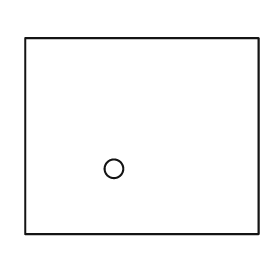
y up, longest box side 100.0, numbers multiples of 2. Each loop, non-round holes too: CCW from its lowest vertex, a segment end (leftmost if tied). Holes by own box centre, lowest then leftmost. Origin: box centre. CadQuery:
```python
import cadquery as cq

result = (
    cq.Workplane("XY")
    .moveTo(-50.0, -42.0)
    .lineTo(50.0, -42.0)
    .lineTo(50.0, 42.0)
    .lineTo(-50.0, 42.0)
    .close()
    .moveTo(-12.0, -14.0)
    .circle(4.0)
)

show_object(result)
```